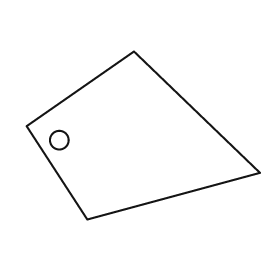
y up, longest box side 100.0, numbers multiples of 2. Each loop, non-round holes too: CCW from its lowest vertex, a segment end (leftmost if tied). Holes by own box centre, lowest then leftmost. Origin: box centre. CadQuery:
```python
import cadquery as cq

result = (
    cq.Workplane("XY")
    .moveTo(-24.0, -36.0)
    .lineTo(50.0, -16.0)
    .lineTo(-4.0, 36.0)
    .lineTo(-50.0, 4.0)
    .close()
    .moveTo(-36.0, -2.0)
    .circle(4.0)
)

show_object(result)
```